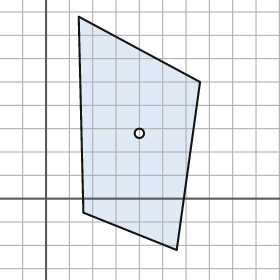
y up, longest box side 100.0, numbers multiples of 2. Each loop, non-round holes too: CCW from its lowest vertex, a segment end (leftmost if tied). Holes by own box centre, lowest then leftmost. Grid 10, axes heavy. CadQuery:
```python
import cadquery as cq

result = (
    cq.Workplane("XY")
    .moveTo(56.0, -22.0)
    .lineTo(66.0, 50.0)
    .lineTo(14.0, 78.0)
    .lineTo(16.0, -6.0)
    .close()
    .moveTo(40.0, 28.0)
    .circle(2.0)
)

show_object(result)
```